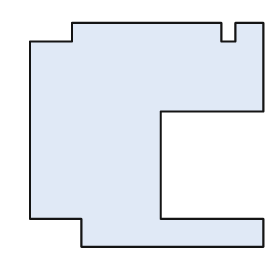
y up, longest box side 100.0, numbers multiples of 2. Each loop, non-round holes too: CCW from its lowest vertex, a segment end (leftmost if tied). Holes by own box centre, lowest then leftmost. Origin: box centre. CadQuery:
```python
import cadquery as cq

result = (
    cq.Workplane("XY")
    .moveTo(-28.0, -48.0)
    .lineTo(50.0, -48.0)
    .lineTo(50.0, -36.0)
    .lineTo(6.0, -36.0)
    .lineTo(6.0, 10.0)
    .lineTo(50.0, 10.0)
    .lineTo(50.0, 48.0)
    .lineTo(38.0, 48.0)
    .lineTo(38.0, 40.0)
    .lineTo(32.0, 40.0)
    .lineTo(32.0, 48.0)
    .lineTo(-32.0, 48.0)
    .lineTo(-32.0, 40.0)
    .lineTo(-50.0, 40.0)
    .lineTo(-50.0, -36.0)
    .lineTo(-28.0, -36.0)
    .close()
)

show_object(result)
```